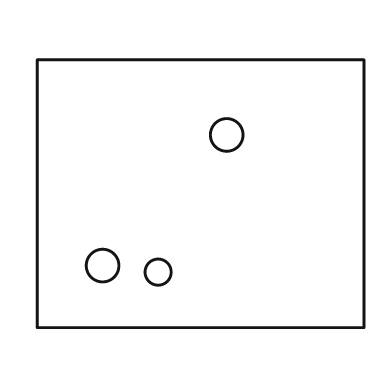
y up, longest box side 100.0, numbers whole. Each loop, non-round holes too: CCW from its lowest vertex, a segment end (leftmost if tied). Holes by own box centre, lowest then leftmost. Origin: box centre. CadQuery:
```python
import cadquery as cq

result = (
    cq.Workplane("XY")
    .moveTo(-50.0, -41.0)
    .lineTo(50.0, -41.0)
    .lineTo(50.0, 41.0)
    .lineTo(-50.0, 41.0)
    .close()
    .moveTo(-13.0, -24.0)
    .circle(4.0)
    .moveTo(-30.0, -22.0)
    .circle(5.0)
    .moveTo(8.0, 18.0)
    .circle(5.0)
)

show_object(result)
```